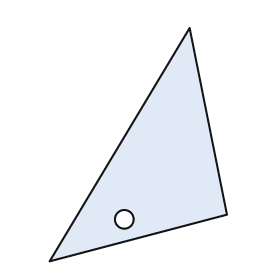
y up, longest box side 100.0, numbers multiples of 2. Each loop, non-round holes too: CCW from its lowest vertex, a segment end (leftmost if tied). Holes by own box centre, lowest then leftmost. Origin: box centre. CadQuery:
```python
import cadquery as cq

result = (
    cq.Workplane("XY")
    .moveTo(-38.0, -50.0)
    .lineTo(38.0, -30.0)
    .lineTo(22.0, 50.0)
    .close()
    .moveTo(-6.0, -32.0)
    .circle(4.0)
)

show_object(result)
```